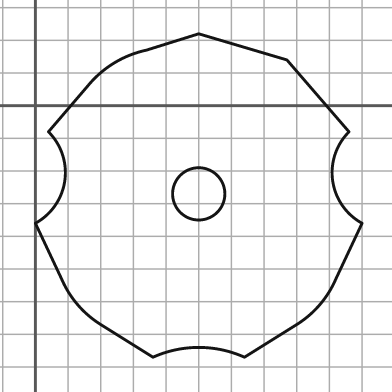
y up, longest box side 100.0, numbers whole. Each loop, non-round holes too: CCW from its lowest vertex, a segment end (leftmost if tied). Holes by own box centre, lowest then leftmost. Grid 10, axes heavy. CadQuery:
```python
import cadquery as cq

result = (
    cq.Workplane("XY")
    .moveTo(36.0, -77.0)
    .threePointArc((50.0, -74.0), (64.0, -77.0))
    .lineTo(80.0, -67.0)
    .threePointArc((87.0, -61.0), (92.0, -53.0))
    .lineTo(100.0, -36.0)
    .threePointArc((91.0, -23.0), (96.0, -8.0))
    .lineTo(77.0, 14.0)
    .lineTo(50.0, 22.0)
    .lineTo(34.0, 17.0)
    .threePointArc((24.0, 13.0), (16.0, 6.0))
    .lineTo(4.0, -8.0)
    .threePointArc((9.0, -23.0), (0.0, -36.0))
    .lineTo(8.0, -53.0)
    .threePointArc((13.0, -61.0), (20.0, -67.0))
    .close()
    .moveTo(50.0, -27.0)
    .circle(8.0)
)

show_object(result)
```